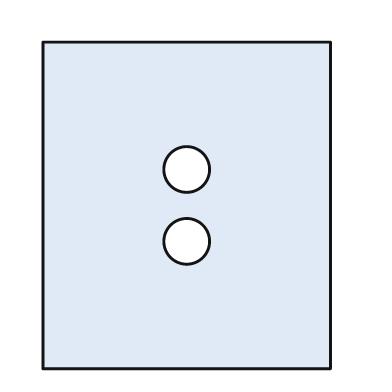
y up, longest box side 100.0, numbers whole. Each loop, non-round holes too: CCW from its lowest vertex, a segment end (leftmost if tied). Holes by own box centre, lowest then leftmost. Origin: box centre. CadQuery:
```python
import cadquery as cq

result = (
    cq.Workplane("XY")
    .moveTo(-44.0, -50.0)
    .lineTo(44.0, -50.0)
    .lineTo(44.0, 50.0)
    .lineTo(-44.0, 50.0)
    .close()
    .moveTo(0.0, -11.0)
    .circle(7.0)
    .moveTo(0.0, 11.0)
    .circle(7.0)
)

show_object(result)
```